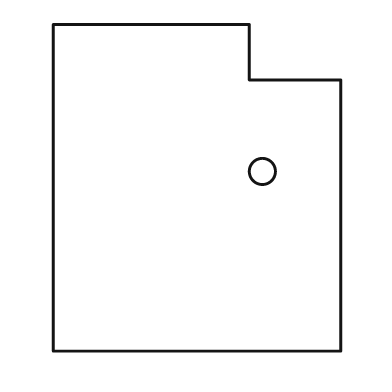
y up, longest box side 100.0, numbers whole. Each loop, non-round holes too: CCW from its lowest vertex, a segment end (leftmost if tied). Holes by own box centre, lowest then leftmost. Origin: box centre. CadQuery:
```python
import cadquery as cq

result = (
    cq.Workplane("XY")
    .moveTo(-44.0, -50.0)
    .lineTo(44.0, -50.0)
    .lineTo(44.0, 33.0)
    .lineTo(16.0, 33.0)
    .lineTo(16.0, 50.0)
    .lineTo(-44.0, 50.0)
    .close()
    .moveTo(20.0, 5.0)
    .circle(4.0)
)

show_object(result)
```